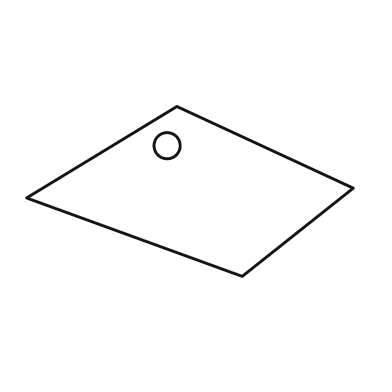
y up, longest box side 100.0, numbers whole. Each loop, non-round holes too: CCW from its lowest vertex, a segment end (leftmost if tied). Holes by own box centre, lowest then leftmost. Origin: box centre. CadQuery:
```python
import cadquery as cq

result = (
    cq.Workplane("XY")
    .moveTo(16.0, -26.0)
    .lineTo(50.0, 1.0)
    .lineTo(-4.0, 26.0)
    .lineTo(-50.0, -2.0)
    .close()
    .moveTo(-7.0, 14.0)
    .circle(4.0)
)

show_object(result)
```